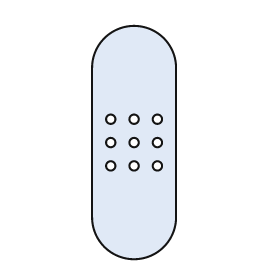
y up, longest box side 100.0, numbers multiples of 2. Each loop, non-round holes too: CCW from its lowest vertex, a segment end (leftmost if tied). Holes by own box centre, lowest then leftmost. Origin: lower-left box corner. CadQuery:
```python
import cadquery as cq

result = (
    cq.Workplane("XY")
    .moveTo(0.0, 18.0)
    .threePointArc((18.0, 0.0), (36.0, 18.0))
    .lineTo(36.0, 82.0)
    .threePointArc((18.0, 100.0), (0.0, 82.0))
    .close()
    .moveTo(8.0, 40.0)
    .circle(2.0)
    .moveTo(18.0, 40.0)
    .circle(2.0)
    .moveTo(28.0, 40.0)
    .circle(2.0)
    .moveTo(8.0, 50.0)
    .circle(2.0)
    .moveTo(18.0, 50.0)
    .circle(2.0)
    .moveTo(28.0, 50.0)
    .circle(2.0)
    .moveTo(8.0, 60.0)
    .circle(2.0)
    .moveTo(18.0, 60.0)
    .circle(2.0)
    .moveTo(28.0, 60.0)
    .circle(2.0)
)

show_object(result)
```